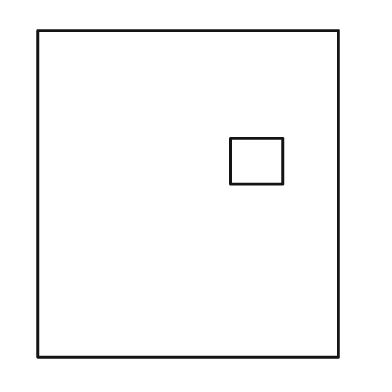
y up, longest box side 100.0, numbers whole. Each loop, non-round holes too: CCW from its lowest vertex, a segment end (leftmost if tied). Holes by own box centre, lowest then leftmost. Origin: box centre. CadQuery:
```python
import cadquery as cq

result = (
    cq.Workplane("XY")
    .moveTo(-46.0, -50.0)
    .lineTo(46.0, -50.0)
    .lineTo(46.0, 50.0)
    .lineTo(-46.0, 50.0)
    .close()
    .moveTo(13.0, 3.0)
    .lineTo(29.0, 3.0)
    .lineTo(29.0, 17.0)
    .lineTo(13.0, 17.0)
    .close()
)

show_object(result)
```